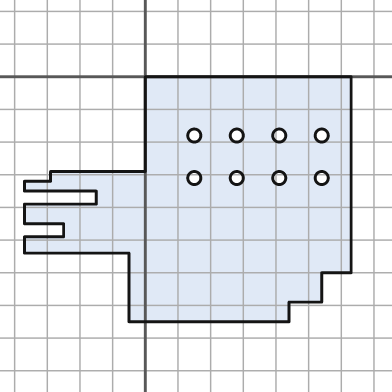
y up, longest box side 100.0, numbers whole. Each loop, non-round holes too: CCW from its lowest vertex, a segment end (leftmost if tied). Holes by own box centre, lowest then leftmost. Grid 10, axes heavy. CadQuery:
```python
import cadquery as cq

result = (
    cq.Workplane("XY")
    .moveTo(-5.0, -75.0)
    .lineTo(44.0, -75.0)
    .lineTo(44.0, -69.0)
    .lineTo(54.0, -69.0)
    .lineTo(54.0, -60.0)
    .lineTo(63.0, -60.0)
    .lineTo(63.0, 0.0)
    .lineTo(0.0, 0.0)
    .lineTo(0.0, -29.0)
    .lineTo(-29.0, -29.0)
    .lineTo(-29.0, -32.0)
    .lineTo(-37.0, -32.0)
    .lineTo(-37.0, -35.0)
    .lineTo(-15.0, -35.0)
    .lineTo(-15.0, -39.0)
    .lineTo(-37.0, -39.0)
    .lineTo(-37.0, -45.0)
    .lineTo(-25.0, -45.0)
    .lineTo(-25.0, -49.0)
    .lineTo(-37.0, -49.0)
    .lineTo(-37.0, -54.0)
    .lineTo(-5.0, -54.0)
    .close()
    .moveTo(15.0, -31.0)
    .circle(2.0)
    .moveTo(28.0, -31.0)
    .circle(2.0)
    .moveTo(41.0, -31.0)
    .circle(2.0)
    .moveTo(54.0, -31.0)
    .circle(2.0)
    .moveTo(15.0, -18.0)
    .circle(2.0)
    .moveTo(28.0, -18.0)
    .circle(2.0)
    .moveTo(41.0, -18.0)
    .circle(2.0)
    .moveTo(54.0, -18.0)
    .circle(2.0)
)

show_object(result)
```